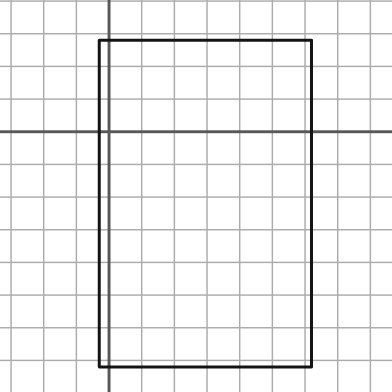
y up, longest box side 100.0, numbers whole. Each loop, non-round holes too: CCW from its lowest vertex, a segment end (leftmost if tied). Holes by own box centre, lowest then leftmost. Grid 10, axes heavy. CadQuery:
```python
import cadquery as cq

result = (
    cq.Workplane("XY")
    .moveTo(-3.0, -72.0)
    .lineTo(62.0, -72.0)
    .lineTo(62.0, 28.0)
    .lineTo(-3.0, 28.0)
    .close()
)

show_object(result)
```